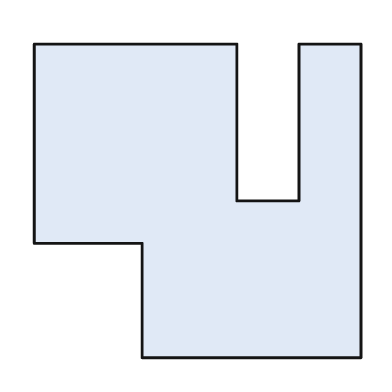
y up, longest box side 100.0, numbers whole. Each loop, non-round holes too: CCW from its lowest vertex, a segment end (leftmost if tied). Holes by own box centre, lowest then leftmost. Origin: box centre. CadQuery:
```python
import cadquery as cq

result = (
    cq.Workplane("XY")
    .moveTo(-17.0, -48.0)
    .lineTo(50.0, -48.0)
    .lineTo(50.0, 48.0)
    .lineTo(31.0, 48.0)
    .lineTo(31.0, 0.0)
    .lineTo(12.0, 0.0)
    .lineTo(12.0, 48.0)
    .lineTo(-50.0, 48.0)
    .lineTo(-50.0, -13.0)
    .lineTo(-17.0, -13.0)
    .close()
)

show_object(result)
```